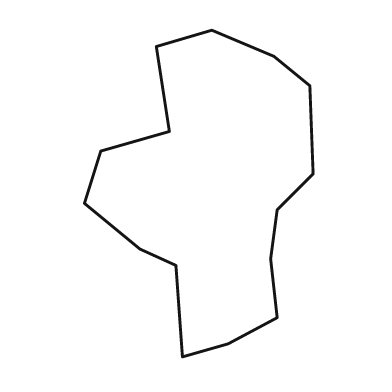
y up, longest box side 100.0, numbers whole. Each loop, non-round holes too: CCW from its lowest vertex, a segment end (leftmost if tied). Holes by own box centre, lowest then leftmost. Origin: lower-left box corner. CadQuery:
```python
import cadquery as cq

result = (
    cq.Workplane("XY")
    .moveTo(30.0, 0.0)
    .lineTo(44.0, 4.0)
    .lineTo(59.0, 12.0)
    .lineTo(57.0, 30.0)
    .lineTo(59.0, 45.0)
    .lineTo(70.0, 56.0)
    .lineTo(69.0, 83.0)
    .lineTo(58.0, 92.0)
    .lineTo(39.0, 100.0)
    .lineTo(22.0, 95.0)
    .lineTo(26.0, 69.0)
    .lineTo(5.0, 63.0)
    .lineTo(0.0, 47.0)
    .lineTo(17.0, 33.0)
    .lineTo(28.0, 28.0)
    .close()
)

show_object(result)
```